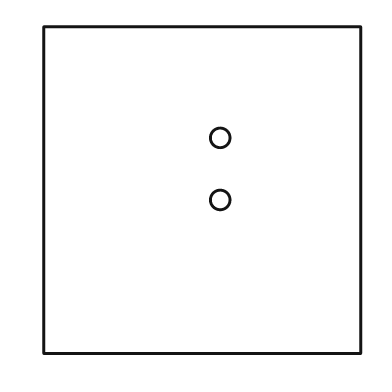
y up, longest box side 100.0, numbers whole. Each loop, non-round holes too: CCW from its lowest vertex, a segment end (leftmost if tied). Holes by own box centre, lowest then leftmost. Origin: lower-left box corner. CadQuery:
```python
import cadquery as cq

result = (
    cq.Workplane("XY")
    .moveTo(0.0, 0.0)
    .lineTo(97.0, 0.0)
    .lineTo(97.0, 100.0)
    .lineTo(0.0, 100.0)
    .close()
    .moveTo(54.0, 47.0)
    .circle(3.0)
    .moveTo(54.0, 66.0)
    .circle(3.0)
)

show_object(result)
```